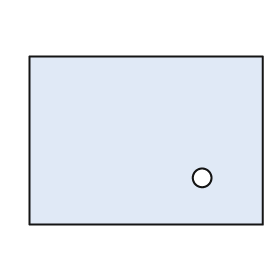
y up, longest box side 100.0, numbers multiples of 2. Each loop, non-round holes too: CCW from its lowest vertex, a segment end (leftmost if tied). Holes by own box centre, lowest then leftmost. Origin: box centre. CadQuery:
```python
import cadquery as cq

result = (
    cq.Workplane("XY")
    .moveTo(-50.0, -36.0)
    .lineTo(50.0, -36.0)
    .lineTo(50.0, 36.0)
    .lineTo(-50.0, 36.0)
    .close()
    .moveTo(24.0, -16.0)
    .circle(4.0)
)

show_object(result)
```